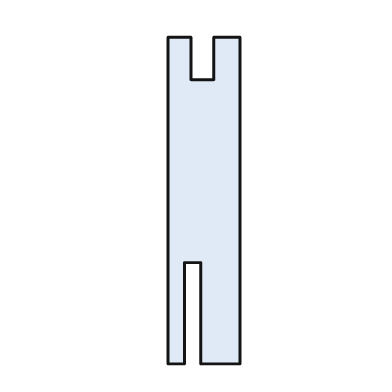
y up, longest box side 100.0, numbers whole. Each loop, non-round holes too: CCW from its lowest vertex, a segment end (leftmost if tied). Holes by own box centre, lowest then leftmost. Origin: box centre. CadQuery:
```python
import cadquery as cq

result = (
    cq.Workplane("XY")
    .moveTo(-11.0, -50.0)
    .lineTo(-6.0, -50.0)
    .lineTo(-6.0, -19.0)
    .lineTo(-1.0, -19.0)
    .lineTo(-1.0, -50.0)
    .lineTo(11.0, -50.0)
    .lineTo(11.0, 50.0)
    .lineTo(3.0, 50.0)
    .lineTo(3.0, 37.0)
    .lineTo(-4.0, 37.0)
    .lineTo(-4.0, 50.0)
    .lineTo(-11.0, 50.0)
    .close()
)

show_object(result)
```